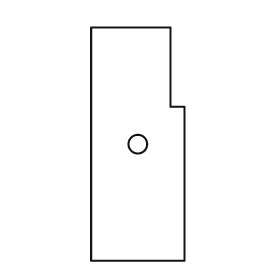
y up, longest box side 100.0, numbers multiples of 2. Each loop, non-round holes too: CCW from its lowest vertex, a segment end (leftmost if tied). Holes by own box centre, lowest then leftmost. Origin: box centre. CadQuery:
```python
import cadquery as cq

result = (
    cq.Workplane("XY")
    .moveTo(-20.0, -50.0)
    .lineTo(20.0, -50.0)
    .lineTo(20.0, 16.0)
    .lineTo(14.0, 16.0)
    .lineTo(14.0, 50.0)
    .lineTo(-20.0, 50.0)
    .close()
    .moveTo(0.0, 0.0)
    .circle(4.0)
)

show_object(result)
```